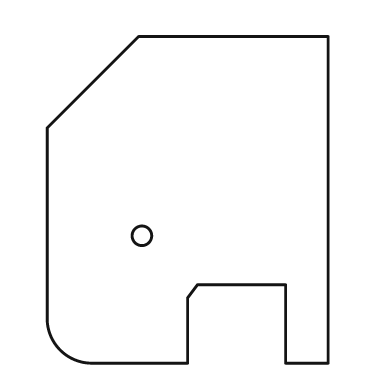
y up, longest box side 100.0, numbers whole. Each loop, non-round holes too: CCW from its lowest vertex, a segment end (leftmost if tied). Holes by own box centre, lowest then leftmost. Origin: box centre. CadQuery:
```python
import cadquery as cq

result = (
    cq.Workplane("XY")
    .moveTo(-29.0, -50.0)
    .lineTo(0.0, -50.0)
    .lineTo(0.0, -30.0)
    .lineTo(3.0, -26.0)
    .lineTo(30.0, -26.0)
    .lineTo(30.0, -50.0)
    .lineTo(43.0, -50.0)
    .lineTo(43.0, 50.0)
    .lineTo(-15.0, 50.0)
    .lineTo(-43.0, 22.0)
    .lineTo(-43.0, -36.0)
    .threePointArc((-39.0, -46.0), (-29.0, -50.0))
    .close()
    .moveTo(-14.0, -11.0)
    .circle(3.0)
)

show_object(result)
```